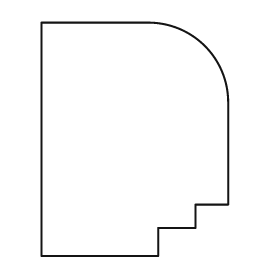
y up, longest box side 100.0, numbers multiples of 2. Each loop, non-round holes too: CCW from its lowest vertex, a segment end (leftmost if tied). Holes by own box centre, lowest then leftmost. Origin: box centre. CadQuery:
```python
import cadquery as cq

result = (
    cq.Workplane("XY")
    .moveTo(-40.0, -50.0)
    .lineTo(10.0, -50.0)
    .lineTo(10.0, -38.0)
    .lineTo(26.0, -38.0)
    .lineTo(26.0, -28.0)
    .lineTo(40.0, -28.0)
    .lineTo(40.0, 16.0)
    .threePointArc((30.0, 40.0), (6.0, 50.0))
    .lineTo(-40.0, 50.0)
    .close()
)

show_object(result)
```